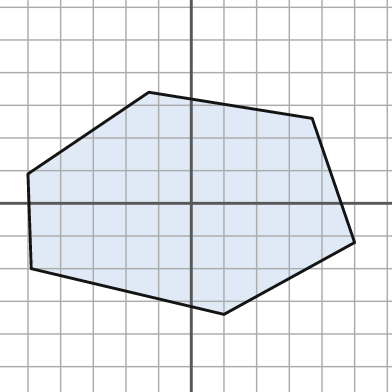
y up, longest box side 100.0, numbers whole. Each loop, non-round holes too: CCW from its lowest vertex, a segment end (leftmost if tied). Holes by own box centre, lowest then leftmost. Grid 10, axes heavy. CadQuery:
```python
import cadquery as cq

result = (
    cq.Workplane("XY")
    .moveTo(10.0, -34.0)
    .lineTo(50.0, -12.0)
    .lineTo(37.0, 26.0)
    .lineTo(-13.0, 34.0)
    .lineTo(-50.0, 9.0)
    .lineTo(-49.0, -20.0)
    .close()
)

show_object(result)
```